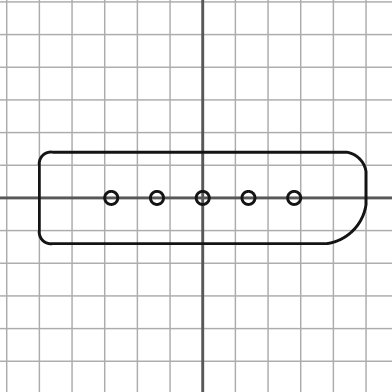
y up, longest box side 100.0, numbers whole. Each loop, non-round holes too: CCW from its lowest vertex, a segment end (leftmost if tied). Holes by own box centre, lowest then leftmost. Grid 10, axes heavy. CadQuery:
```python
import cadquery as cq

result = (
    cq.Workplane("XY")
    .moveTo(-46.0, -14.0)
    .lineTo(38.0, -14.0)
    .threePointArc((46.0, -10.0), (50.0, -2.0))
    .lineTo(50.0, 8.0)
    .threePointArc((48.0, 12.0), (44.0, 14.0))
    .lineTo(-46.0, 14.0)
    .threePointArc((-49.0, 13.0), (-50.0, 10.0))
    .lineTo(-50.0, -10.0)
    .threePointArc((-49.0, -13.0), (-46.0, -14.0))
    .close()
    .moveTo(-28.0, 0.0)
    .circle(2.0)
    .moveTo(-14.0, 0.0)
    .circle(2.0)
    .moveTo(0.0, 0.0)
    .circle(2.0)
    .moveTo(14.0, 0.0)
    .circle(2.0)
    .moveTo(28.0, 0.0)
    .circle(2.0)
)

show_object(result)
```